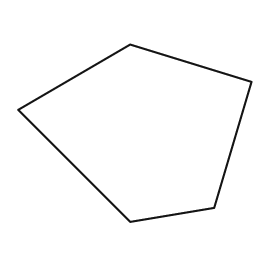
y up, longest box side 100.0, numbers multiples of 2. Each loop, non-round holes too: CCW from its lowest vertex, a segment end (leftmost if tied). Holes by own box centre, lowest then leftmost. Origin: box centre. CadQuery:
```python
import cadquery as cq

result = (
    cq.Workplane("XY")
    .moveTo(-2.0, -38.0)
    .lineTo(34.0, -32.0)
    .lineTo(50.0, 22.0)
    .lineTo(-2.0, 38.0)
    .lineTo(-50.0, 10.0)
    .close()
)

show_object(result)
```